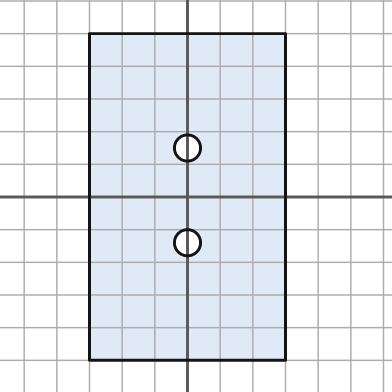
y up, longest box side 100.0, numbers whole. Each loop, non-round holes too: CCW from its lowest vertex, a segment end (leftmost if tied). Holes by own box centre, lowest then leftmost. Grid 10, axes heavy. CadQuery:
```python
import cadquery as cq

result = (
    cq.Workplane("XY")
    .moveTo(-30.0, -50.0)
    .lineTo(30.0, -50.0)
    .lineTo(30.0, 50.0)
    .lineTo(-30.0, 50.0)
    .close()
    .moveTo(0.0, -14.0)
    .circle(4.0)
    .moveTo(0.0, 15.0)
    .circle(4.0)
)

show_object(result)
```